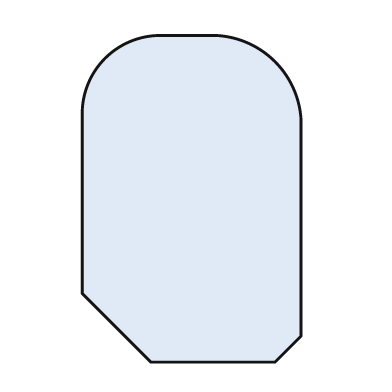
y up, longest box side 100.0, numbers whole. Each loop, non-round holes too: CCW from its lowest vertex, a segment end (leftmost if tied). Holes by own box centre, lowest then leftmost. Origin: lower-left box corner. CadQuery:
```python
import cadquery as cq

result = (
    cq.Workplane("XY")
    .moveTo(21.0, 0.0)
    .lineTo(59.0, 0.0)
    .lineTo(67.0, 8.0)
    .lineTo(67.0, 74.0)
    .threePointArc((59.0, 92.0), (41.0, 100.0))
    .lineTo(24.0, 100.0)
    .threePointArc((7.0, 93.0), (0.0, 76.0))
    .lineTo(0.0, 21.0)
    .close()
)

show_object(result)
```